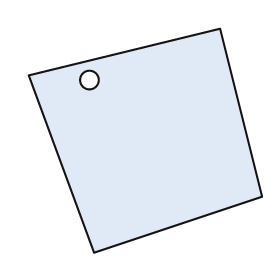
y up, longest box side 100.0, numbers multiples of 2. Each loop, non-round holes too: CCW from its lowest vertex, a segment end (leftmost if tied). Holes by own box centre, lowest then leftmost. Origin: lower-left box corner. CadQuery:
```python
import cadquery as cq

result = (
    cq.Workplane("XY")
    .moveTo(28.0, 0.0)
    .lineTo(100.0, 24.0)
    .lineTo(82.0, 96.0)
    .lineTo(0.0, 76.0)
    .close()
    .moveTo(26.0, 74.0)
    .circle(4.0)
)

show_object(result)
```